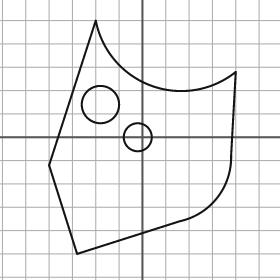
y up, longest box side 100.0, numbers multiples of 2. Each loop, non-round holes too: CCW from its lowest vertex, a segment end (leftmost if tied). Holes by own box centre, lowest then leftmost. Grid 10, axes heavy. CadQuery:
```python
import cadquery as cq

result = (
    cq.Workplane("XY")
    .moveTo(-28.0, -50.0)
    .lineTo(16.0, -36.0)
    .threePointArc((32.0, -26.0), (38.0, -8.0))
    .lineTo(40.0, 28.0)
    .threePointArc((4.0, 22.0), (-20.0, 50.0))
    .lineTo(-40.0, -12.0)
    .close()
    .moveTo(-2.0, 0.0)
    .circle(6.0)
    .moveTo(-18.0, 14.0)
    .circle(8.0)
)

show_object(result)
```